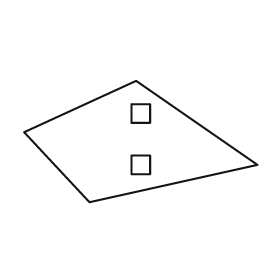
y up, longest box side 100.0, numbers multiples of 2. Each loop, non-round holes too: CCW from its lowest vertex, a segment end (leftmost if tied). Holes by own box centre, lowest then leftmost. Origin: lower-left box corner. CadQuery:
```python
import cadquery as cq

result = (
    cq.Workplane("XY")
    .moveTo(28.0, 0.0)
    .lineTo(100.0, 16.0)
    .lineTo(48.0, 52.0)
    .lineTo(0.0, 30.0)
    .close()
    .moveTo(46.0, 12.0)
    .lineTo(54.0, 12.0)
    .lineTo(54.0, 20.0)
    .lineTo(46.0, 20.0)
    .close()
    .moveTo(46.0, 34.0)
    .lineTo(54.0, 34.0)
    .lineTo(54.0, 42.0)
    .lineTo(46.0, 42.0)
    .close()
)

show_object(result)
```